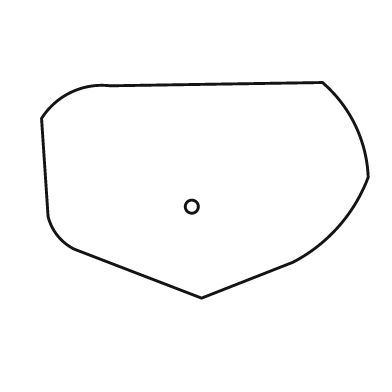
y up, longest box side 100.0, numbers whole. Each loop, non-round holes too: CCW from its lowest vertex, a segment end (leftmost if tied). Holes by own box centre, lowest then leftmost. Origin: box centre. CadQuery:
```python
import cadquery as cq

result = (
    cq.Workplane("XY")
    .moveTo(-1.0, -33.0)
    .lineTo(27.0, -22.0)
    .threePointArc((41.0, -11.0), (50.0, 4.0))
    .threePointArc((46.0, 20.0), (36.0, 33.0))
    .lineTo(-29.0, 32.0)
    .threePointArc((-41.0, 30.0), (-50.0, 22.0))
    .lineTo(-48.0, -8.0)
    .threePointArc((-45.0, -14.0), (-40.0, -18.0))
    .close()
    .moveTo(-4.0, -5.0)
    .circle(2.0)
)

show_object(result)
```